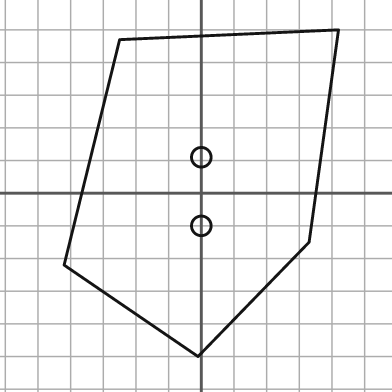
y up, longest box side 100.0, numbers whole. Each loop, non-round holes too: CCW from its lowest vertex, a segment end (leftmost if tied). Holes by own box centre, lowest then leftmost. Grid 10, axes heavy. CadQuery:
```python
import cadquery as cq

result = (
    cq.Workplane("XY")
    .moveTo(-1.0, -50.0)
    .lineTo(33.0, -15.0)
    .lineTo(42.0, 50.0)
    .lineTo(-25.0, 47.0)
    .lineTo(-42.0, -22.0)
    .close()
    .moveTo(0.0, -10.0)
    .circle(3.0)
    .moveTo(0.0, 11.0)
    .circle(3.0)
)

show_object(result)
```